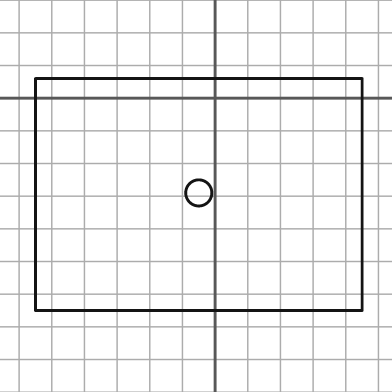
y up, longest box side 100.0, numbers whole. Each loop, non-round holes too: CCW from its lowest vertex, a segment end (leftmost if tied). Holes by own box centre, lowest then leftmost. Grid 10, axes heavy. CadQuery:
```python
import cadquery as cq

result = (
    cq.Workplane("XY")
    .moveTo(-55.0, -65.0)
    .lineTo(45.0, -65.0)
    .lineTo(45.0, 6.0)
    .lineTo(-55.0, 6.0)
    .close()
    .moveTo(-5.0, -29.0)
    .circle(4.0)
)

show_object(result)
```